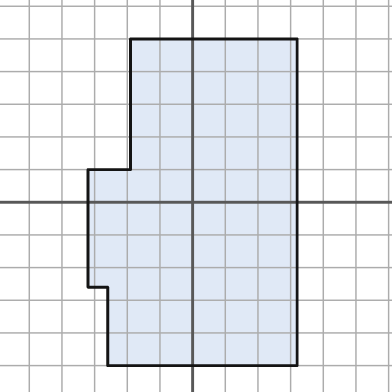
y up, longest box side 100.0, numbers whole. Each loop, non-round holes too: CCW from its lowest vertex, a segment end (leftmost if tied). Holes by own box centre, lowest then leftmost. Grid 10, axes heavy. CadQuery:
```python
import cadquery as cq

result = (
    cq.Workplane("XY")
    .moveTo(-26.0, -50.0)
    .lineTo(32.0, -50.0)
    .lineTo(32.0, 50.0)
    .lineTo(-19.0, 50.0)
    .lineTo(-19.0, 10.0)
    .lineTo(-32.0, 10.0)
    .lineTo(-32.0, -26.0)
    .lineTo(-26.0, -26.0)
    .close()
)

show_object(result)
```